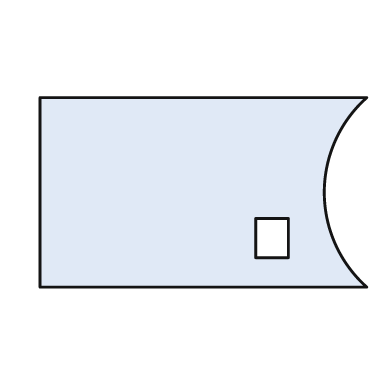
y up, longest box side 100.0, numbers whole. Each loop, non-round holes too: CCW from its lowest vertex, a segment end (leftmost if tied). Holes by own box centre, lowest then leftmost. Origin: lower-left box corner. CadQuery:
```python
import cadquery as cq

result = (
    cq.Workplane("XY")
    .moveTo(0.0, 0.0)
    .lineTo(100.0, 0.0)
    .threePointArc((87.0, 29.0), (100.0, 58.0))
    .lineTo(0.0, 58.0)
    .close()
    .moveTo(66.0, 9.0)
    .lineTo(76.0, 9.0)
    .lineTo(76.0, 21.0)
    .lineTo(66.0, 21.0)
    .close()
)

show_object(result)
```